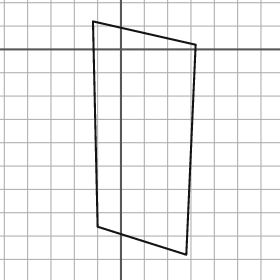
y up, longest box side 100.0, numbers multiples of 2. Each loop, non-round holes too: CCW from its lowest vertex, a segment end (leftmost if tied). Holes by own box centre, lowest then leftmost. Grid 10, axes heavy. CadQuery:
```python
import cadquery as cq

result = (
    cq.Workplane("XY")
    .moveTo(28.0, -88.0)
    .lineTo(32.0, 2.0)
    .lineTo(-12.0, 12.0)
    .lineTo(-10.0, -76.0)
    .close()
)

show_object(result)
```